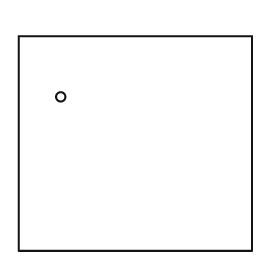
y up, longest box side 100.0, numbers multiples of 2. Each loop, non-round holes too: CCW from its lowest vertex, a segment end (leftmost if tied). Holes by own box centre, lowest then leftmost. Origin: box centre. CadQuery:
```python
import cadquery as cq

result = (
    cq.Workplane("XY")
    .moveTo(-50.0, -46.0)
    .lineTo(50.0, -46.0)
    .lineTo(50.0, 46.0)
    .lineTo(-50.0, 46.0)
    .close()
    .moveTo(-32.0, 20.0)
    .circle(2.0)
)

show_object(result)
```